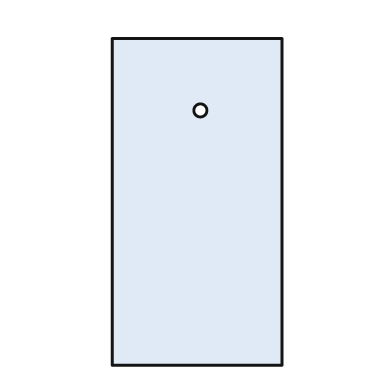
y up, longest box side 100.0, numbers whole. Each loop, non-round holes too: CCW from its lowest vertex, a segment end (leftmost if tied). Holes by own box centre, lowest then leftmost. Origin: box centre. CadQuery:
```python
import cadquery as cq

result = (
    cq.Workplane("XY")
    .moveTo(-26.0, -50.0)
    .lineTo(26.0, -50.0)
    .lineTo(26.0, 50.0)
    .lineTo(-26.0, 50.0)
    .close()
    .moveTo(1.0, 28.0)
    .circle(2.0)
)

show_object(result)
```